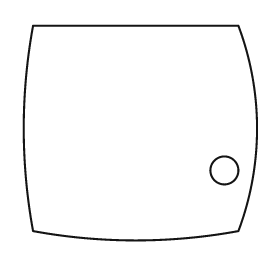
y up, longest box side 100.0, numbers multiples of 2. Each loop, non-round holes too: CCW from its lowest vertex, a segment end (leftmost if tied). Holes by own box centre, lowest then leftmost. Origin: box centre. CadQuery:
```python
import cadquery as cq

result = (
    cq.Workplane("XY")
    .moveTo(-46.0, -42.0)
    .threePointArc((-2.0, -46.0), (42.0, -42.0))
    .threePointArc((50.0, 2.0), (42.0, 46.0))
    .lineTo(-46.0, 46.0)
    .threePointArc((-50.0, 2.0), (-46.0, -42.0))
    .close()
    .moveTo(36.0, -16.0)
    .circle(6.0)
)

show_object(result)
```